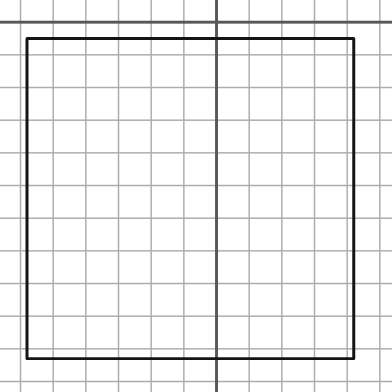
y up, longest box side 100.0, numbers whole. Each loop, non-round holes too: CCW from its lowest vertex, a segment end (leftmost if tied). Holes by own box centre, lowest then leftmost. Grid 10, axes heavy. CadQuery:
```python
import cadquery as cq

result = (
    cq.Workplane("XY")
    .moveTo(-58.0, -103.0)
    .lineTo(42.0, -103.0)
    .lineTo(42.0, -5.0)
    .lineTo(-58.0, -5.0)
    .close()
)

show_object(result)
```